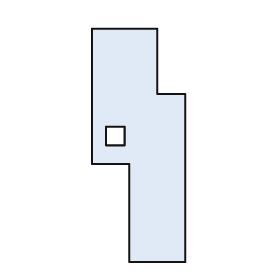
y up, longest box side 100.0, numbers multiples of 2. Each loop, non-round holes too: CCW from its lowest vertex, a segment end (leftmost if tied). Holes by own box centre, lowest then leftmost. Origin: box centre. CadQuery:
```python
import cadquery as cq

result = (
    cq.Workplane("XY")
    .moveTo(-4.0, -50.0)
    .lineTo(20.0, -50.0)
    .lineTo(20.0, 22.0)
    .lineTo(8.0, 22.0)
    .lineTo(8.0, 50.0)
    .lineTo(-20.0, 50.0)
    .lineTo(-20.0, -8.0)
    .lineTo(-4.0, -8.0)
    .close()
    .moveTo(-14.0, 0.0)
    .lineTo(-6.0, 0.0)
    .lineTo(-6.0, 8.0)
    .lineTo(-14.0, 8.0)
    .close()
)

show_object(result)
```